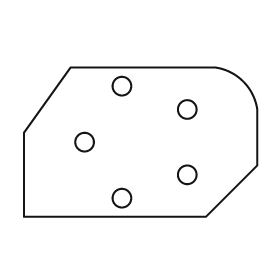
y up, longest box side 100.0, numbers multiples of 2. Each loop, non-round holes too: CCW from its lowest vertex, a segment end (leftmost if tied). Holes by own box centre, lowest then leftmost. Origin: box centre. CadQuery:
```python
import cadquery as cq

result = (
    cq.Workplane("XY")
    .moveTo(-50.0, -32.0)
    .lineTo(28.0, -32.0)
    .lineTo(50.0, -10.0)
    .lineTo(50.0, 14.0)
    .threePointArc((44.0, 26.0), (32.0, 32.0))
    .lineTo(-30.0, 32.0)
    .lineTo(-50.0, 4.0)
    .close()
    .moveTo(-8.0, -24.0)
    .circle(4.0)
    .moveTo(20.0, -14.0)
    .circle(4.0)
    .moveTo(-24.0, 0.0)
    .circle(4.0)
    .moveTo(20.0, 14.0)
    .circle(4.0)
    .moveTo(-8.0, 24.0)
    .circle(4.0)
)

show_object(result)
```